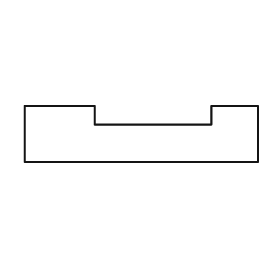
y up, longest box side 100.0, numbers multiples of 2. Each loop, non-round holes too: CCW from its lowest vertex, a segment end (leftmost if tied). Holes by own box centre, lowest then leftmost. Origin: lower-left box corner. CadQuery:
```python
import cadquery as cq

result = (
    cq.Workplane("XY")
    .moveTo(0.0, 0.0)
    .lineTo(100.0, 0.0)
    .lineTo(100.0, 24.0)
    .lineTo(80.0, 24.0)
    .lineTo(80.0, 16.0)
    .lineTo(30.0, 16.0)
    .lineTo(30.0, 24.0)
    .lineTo(0.0, 24.0)
    .close()
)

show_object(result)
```